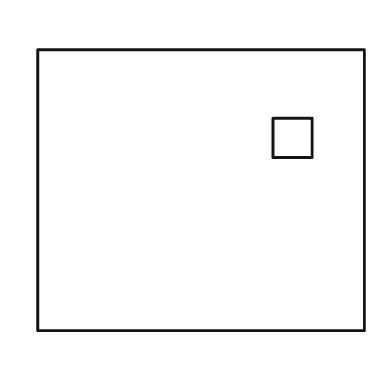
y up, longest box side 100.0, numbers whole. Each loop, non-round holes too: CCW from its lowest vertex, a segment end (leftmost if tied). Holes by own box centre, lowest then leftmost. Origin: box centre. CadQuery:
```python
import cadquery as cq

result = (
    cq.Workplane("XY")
    .moveTo(-50.0, -43.0)
    .lineTo(50.0, -43.0)
    .lineTo(50.0, 43.0)
    .lineTo(-50.0, 43.0)
    .close()
    .moveTo(22.0, 10.0)
    .lineTo(34.0, 10.0)
    .lineTo(34.0, 22.0)
    .lineTo(22.0, 22.0)
    .close()
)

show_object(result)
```